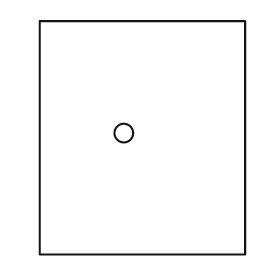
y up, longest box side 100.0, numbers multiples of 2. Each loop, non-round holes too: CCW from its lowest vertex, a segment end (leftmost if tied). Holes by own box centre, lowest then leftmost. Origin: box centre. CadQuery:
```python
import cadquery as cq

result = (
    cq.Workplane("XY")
    .moveTo(-44.0, -50.0)
    .lineTo(44.0, -50.0)
    .lineTo(44.0, 50.0)
    .lineTo(-44.0, 50.0)
    .close()
    .moveTo(-8.0, 2.0)
    .circle(4.0)
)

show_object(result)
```